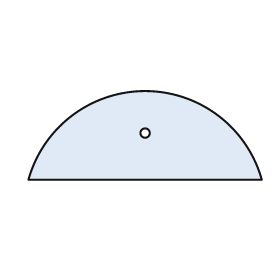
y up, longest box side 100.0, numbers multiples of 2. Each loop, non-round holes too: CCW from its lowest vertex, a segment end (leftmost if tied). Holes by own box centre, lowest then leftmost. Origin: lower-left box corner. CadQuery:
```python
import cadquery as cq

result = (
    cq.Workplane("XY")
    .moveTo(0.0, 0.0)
    .lineTo(100.0, 0.0)
    .threePointArc((50.0, 38.0), (0.0, 0.0))
    .close()
    .moveTo(50.0, 20.0)
    .circle(2.0)
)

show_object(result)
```